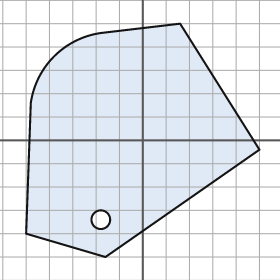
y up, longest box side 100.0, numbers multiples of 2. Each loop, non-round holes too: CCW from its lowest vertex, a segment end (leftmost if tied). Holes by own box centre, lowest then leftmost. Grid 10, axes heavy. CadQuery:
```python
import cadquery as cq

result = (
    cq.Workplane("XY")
    .moveTo(-16.0, -50.0)
    .lineTo(50.0, -4.0)
    .lineTo(16.0, 50.0)
    .lineTo(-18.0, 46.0)
    .threePointArc((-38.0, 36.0), (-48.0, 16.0))
    .lineTo(-50.0, -40.0)
    .close()
    .moveTo(-18.0, -34.0)
    .circle(4.0)
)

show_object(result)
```